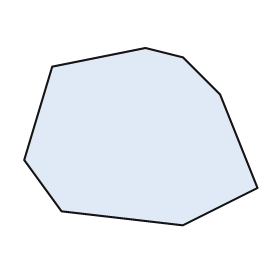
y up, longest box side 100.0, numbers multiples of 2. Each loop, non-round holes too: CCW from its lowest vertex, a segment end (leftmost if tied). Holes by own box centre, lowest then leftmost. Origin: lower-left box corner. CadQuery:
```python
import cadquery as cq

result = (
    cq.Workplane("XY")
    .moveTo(68.0, 0.0)
    .lineTo(100.0, 16.0)
    .lineTo(84.0, 56.0)
    .lineTo(68.0, 72.0)
    .lineTo(52.0, 76.0)
    .lineTo(12.0, 68.0)
    .lineTo(0.0, 28.0)
    .lineTo(16.0, 6.0)
    .close()
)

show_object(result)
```